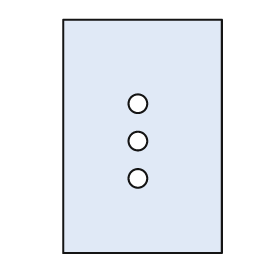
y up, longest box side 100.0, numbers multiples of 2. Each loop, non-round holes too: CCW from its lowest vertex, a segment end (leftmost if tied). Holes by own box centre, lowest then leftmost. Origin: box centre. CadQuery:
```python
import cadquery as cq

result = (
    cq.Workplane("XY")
    .moveTo(-34.0, -50.0)
    .lineTo(34.0, -50.0)
    .lineTo(34.0, 50.0)
    .lineTo(-34.0, 50.0)
    .close()
    .moveTo(-2.0, -18.0)
    .circle(4.0)
    .moveTo(-2.0, -2.0)
    .circle(4.0)
    .moveTo(-2.0, 14.0)
    .circle(4.0)
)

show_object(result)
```